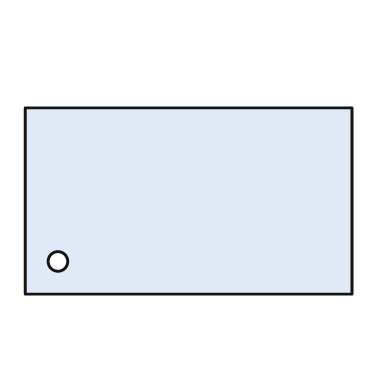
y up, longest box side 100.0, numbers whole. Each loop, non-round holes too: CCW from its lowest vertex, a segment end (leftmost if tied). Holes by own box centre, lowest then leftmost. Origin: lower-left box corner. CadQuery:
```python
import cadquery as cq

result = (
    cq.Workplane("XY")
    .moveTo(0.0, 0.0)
    .lineTo(100.0, 0.0)
    .lineTo(100.0, 57.0)
    .lineTo(0.0, 57.0)
    .close()
    .moveTo(10.0, 10.0)
    .circle(3.0)
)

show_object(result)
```